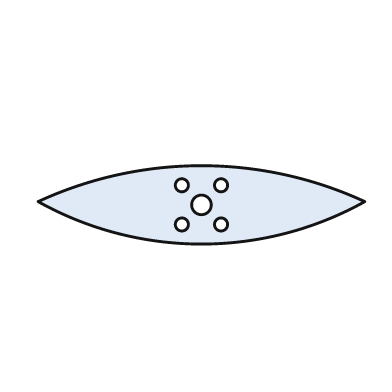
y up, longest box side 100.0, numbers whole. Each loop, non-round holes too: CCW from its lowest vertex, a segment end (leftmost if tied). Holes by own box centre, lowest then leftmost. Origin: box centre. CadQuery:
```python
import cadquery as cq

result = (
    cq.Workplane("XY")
    .moveTo(-50.0, 1.0)
    .threePointArc((0.0, -12.0), (50.0, 1.0))
    .threePointArc((0.0, 12.0), (-50.0, 1.0))
    .close()
    .moveTo(-6.0, -6.0)
    .circle(2.0)
    .moveTo(6.0, -6.0)
    .circle(2.0)
    .moveTo(0.0, 0.0)
    .circle(3.0)
    .moveTo(-6.0, 6.0)
    .circle(2.0)
    .moveTo(6.0, 6.0)
    .circle(2.0)
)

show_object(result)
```